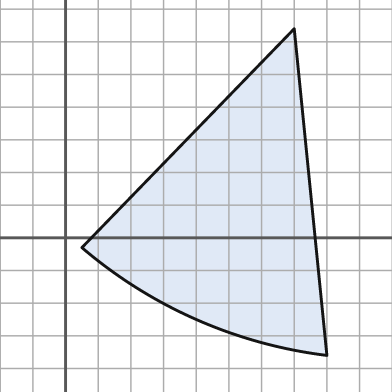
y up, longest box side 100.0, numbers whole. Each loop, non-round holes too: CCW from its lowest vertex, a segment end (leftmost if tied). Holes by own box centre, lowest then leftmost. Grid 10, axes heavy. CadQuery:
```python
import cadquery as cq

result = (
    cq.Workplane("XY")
    .moveTo(80.0, -36.0)
    .lineTo(70.0, 64.0)
    .lineTo(5.0, -3.0)
    .threePointArc((40.0, -25.0), (80.0, -36.0))
    .close()
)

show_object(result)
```